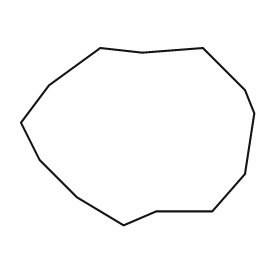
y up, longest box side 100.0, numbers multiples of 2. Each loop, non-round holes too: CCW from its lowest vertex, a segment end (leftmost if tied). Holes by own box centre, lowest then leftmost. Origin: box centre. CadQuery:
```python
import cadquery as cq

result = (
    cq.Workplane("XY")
    .moveTo(-6.0, -38.0)
    .lineTo(8.0, -32.0)
    .lineTo(32.0, -32.0)
    .lineTo(46.0, -16.0)
    .lineTo(50.0, 10.0)
    .lineTo(46.0, 20.0)
    .lineTo(28.0, 38.0)
    .lineTo(2.0, 36.0)
    .lineTo(-16.0, 38.0)
    .lineTo(-38.0, 22.0)
    .lineTo(-50.0, 6.0)
    .lineTo(-42.0, -10.0)
    .lineTo(-26.0, -26.0)
    .close()
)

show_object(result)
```